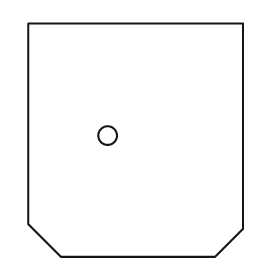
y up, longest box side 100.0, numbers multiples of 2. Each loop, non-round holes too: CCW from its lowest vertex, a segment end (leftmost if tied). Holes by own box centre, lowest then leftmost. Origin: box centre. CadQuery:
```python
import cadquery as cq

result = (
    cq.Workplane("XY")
    .moveTo(-32.0, -50.0)
    .lineTo(34.0, -50.0)
    .lineTo(46.0, -38.0)
    .lineTo(46.0, 50.0)
    .lineTo(-46.0, 50.0)
    .lineTo(-46.0, -36.0)
    .close()
    .moveTo(-12.0, 2.0)
    .circle(4.0)
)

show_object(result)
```